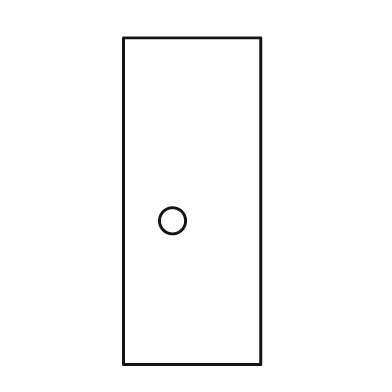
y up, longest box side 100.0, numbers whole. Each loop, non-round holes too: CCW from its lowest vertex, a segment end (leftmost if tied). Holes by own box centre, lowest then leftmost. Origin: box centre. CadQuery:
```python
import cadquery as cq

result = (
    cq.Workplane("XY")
    .moveTo(-21.0, -50.0)
    .lineTo(21.0, -50.0)
    .lineTo(21.0, 50.0)
    .lineTo(-21.0, 50.0)
    .close()
    .moveTo(-6.0, -6.0)
    .circle(4.0)
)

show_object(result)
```